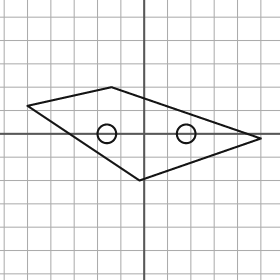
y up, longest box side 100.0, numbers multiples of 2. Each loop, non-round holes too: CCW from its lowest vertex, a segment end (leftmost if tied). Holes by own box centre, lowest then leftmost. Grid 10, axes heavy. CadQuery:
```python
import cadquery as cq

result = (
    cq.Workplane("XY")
    .moveTo(-2.0, -20.0)
    .lineTo(50.0, -2.0)
    .lineTo(-14.0, 20.0)
    .lineTo(-50.0, 12.0)
    .close()
    .moveTo(-16.0, 0.0)
    .circle(4.0)
    .moveTo(18.0, 0.0)
    .circle(4.0)
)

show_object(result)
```